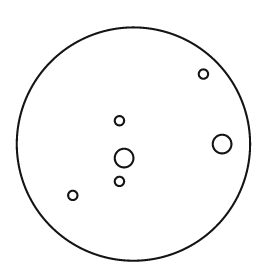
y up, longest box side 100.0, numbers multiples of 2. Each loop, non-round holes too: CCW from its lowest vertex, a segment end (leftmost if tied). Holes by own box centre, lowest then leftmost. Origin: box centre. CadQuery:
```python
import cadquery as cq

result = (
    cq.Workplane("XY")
    .moveTo(0.0, 0.0)
    .circle(50.0)
    .moveTo(-26.0, -22.0)
    .circle(2.0)
    .moveTo(-6.0, -16.0)
    .circle(2.0)
    .moveTo(-4.0, -6.0)
    .circle(4.0)
    .moveTo(38.0, 0.0)
    .circle(4.0)
    .moveTo(-6.0, 10.0)
    .circle(2.0)
    .moveTo(30.0, 30.0)
    .circle(2.0)
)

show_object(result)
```